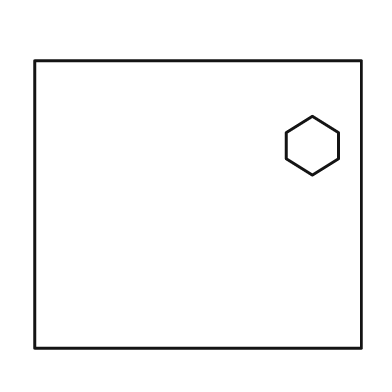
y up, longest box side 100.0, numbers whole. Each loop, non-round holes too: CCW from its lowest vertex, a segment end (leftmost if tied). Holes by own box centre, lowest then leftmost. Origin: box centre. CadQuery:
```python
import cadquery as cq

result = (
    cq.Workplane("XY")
    .moveTo(-50.0, -44.0)
    .lineTo(50.0, -44.0)
    .lineTo(50.0, 44.0)
    .lineTo(-50.0, 44.0)
    .close()
    .moveTo(35.0, 9.0)
    .lineTo(43.0, 14.0)
    .lineTo(43.0, 22.0)
    .lineTo(35.0, 27.0)
    .lineTo(27.0, 22.0)
    .lineTo(27.0, 14.0)
    .close()
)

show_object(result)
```